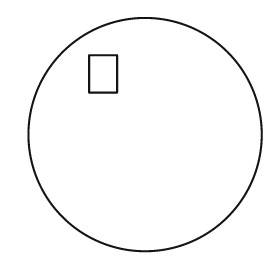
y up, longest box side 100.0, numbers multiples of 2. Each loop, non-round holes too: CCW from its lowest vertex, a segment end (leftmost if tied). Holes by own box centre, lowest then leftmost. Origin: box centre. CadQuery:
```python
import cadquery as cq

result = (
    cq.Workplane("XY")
    .moveTo(0.0, 0.0)
    .circle(50.0)
    .moveTo(-24.0, 18.0)
    .lineTo(-12.0, 18.0)
    .lineTo(-12.0, 34.0)
    .lineTo(-24.0, 34.0)
    .close()
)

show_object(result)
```